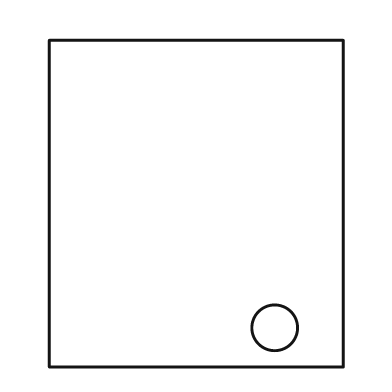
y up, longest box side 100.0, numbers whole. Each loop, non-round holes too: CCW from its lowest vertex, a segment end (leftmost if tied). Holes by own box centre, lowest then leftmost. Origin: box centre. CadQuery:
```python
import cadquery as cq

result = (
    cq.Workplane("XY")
    .moveTo(-45.0, -50.0)
    .lineTo(45.0, -50.0)
    .lineTo(45.0, 50.0)
    .lineTo(-45.0, 50.0)
    .close()
    .moveTo(24.0, -38.0)
    .circle(7.0)
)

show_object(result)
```